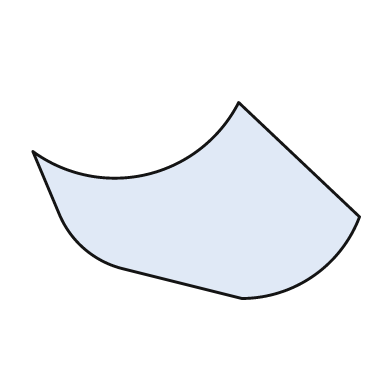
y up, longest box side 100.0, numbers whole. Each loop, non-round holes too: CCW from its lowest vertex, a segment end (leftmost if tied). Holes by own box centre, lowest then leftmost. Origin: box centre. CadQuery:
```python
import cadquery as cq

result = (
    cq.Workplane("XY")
    .moveTo(14.0, -30.0)
    .threePointArc((36.0, -23.0), (50.0, -5.0))
    .lineTo(13.0, 30.0)
    .threePointArc((-15.0, 8.0), (-50.0, 15.0))
    .lineTo(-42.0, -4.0)
    .threePointArc((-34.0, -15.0), (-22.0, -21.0))
    .close()
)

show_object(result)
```